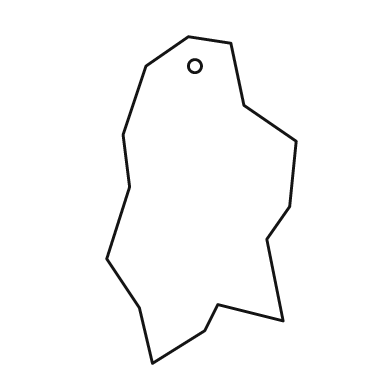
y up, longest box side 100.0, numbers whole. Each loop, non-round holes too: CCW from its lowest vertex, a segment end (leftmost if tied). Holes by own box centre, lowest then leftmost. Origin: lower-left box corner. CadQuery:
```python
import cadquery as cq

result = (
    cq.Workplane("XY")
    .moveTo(14.0, 0.0)
    .lineTo(30.0, 10.0)
    .lineTo(34.0, 18.0)
    .lineTo(54.0, 13.0)
    .lineTo(49.0, 38.0)
    .lineTo(56.0, 48.0)
    .lineTo(58.0, 68.0)
    .lineTo(42.0, 79.0)
    .lineTo(38.0, 98.0)
    .lineTo(25.0, 100.0)
    .lineTo(12.0, 91.0)
    .lineTo(5.0, 70.0)
    .lineTo(7.0, 54.0)
    .lineTo(0.0, 32.0)
    .lineTo(10.0, 17.0)
    .close()
    .moveTo(27.0, 91.0)
    .circle(2.0)
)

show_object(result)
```